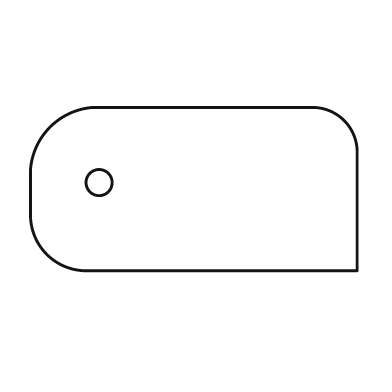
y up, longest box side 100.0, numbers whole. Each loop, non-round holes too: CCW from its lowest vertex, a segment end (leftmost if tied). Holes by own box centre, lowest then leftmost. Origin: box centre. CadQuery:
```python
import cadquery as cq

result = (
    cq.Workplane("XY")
    .moveTo(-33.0, -25.0)
    .lineTo(50.0, -25.0)
    .lineTo(50.0, 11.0)
    .threePointArc((46.0, 21.0), (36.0, 25.0))
    .lineTo(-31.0, 25.0)
    .threePointArc((-44.0, 19.0), (-50.0, 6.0))
    .lineTo(-50.0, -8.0)
    .threePointArc((-45.0, -20.0), (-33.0, -25.0))
    .close()
    .moveTo(-29.0, 2.0)
    .circle(4.0)
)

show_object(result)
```